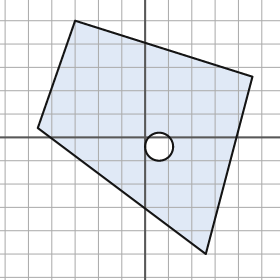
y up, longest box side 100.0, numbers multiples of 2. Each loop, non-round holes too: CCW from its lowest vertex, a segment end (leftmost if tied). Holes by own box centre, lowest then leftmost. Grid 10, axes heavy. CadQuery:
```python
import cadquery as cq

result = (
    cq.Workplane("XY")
    .moveTo(26.0, -50.0)
    .lineTo(46.0, 26.0)
    .lineTo(-30.0, 50.0)
    .lineTo(-46.0, 4.0)
    .close()
    .moveTo(6.0, -4.0)
    .circle(6.0)
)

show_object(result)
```